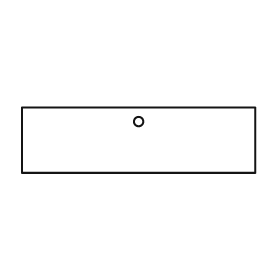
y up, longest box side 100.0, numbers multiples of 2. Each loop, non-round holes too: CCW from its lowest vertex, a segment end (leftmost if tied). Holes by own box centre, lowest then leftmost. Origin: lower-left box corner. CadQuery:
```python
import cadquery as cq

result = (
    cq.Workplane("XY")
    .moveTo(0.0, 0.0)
    .lineTo(100.0, 0.0)
    .lineTo(100.0, 28.0)
    .lineTo(0.0, 28.0)
    .close()
    .moveTo(50.0, 22.0)
    .circle(2.0)
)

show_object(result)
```